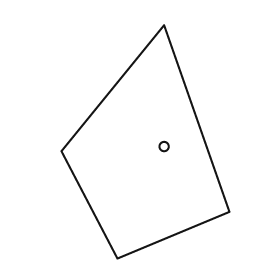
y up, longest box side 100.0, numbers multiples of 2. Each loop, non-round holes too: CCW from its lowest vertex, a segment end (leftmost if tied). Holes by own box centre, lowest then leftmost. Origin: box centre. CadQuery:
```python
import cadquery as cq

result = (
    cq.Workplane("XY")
    .moveTo(-12.0, -50.0)
    .lineTo(36.0, -30.0)
    .lineTo(8.0, 50.0)
    .lineTo(-36.0, -4.0)
    .close()
    .moveTo(8.0, -2.0)
    .circle(2.0)
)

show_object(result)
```